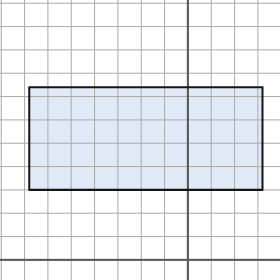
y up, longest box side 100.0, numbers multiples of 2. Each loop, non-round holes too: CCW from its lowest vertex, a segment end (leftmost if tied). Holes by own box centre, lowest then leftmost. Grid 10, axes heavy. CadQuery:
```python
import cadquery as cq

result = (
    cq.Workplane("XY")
    .moveTo(-68.0, 30.0)
    .lineTo(32.0, 30.0)
    .lineTo(32.0, 74.0)
    .lineTo(-68.0, 74.0)
    .close()
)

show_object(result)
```